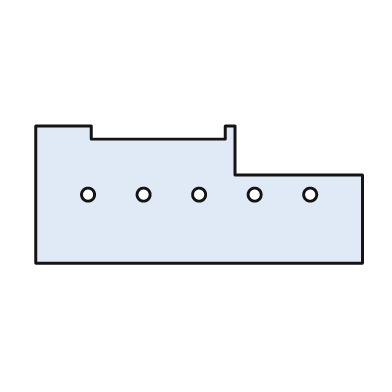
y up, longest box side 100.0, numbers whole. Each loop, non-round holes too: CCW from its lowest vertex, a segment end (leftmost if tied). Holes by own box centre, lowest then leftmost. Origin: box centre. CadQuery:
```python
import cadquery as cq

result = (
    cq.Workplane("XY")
    .moveTo(-50.0, -21.0)
    .lineTo(50.0, -21.0)
    .lineTo(50.0, 6.0)
    .lineTo(11.0, 6.0)
    .lineTo(11.0, 21.0)
    .lineTo(8.0, 21.0)
    .lineTo(8.0, 17.0)
    .lineTo(-33.0, 17.0)
    .lineTo(-33.0, 21.0)
    .lineTo(-50.0, 21.0)
    .close()
    .moveTo(-34.0, 0.0)
    .circle(2.0)
    .moveTo(-17.0, 0.0)
    .circle(2.0)
    .moveTo(0.0, 0.0)
    .circle(2.0)
    .moveTo(17.0, 0.0)
    .circle(2.0)
    .moveTo(34.0, 0.0)
    .circle(2.0)
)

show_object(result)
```